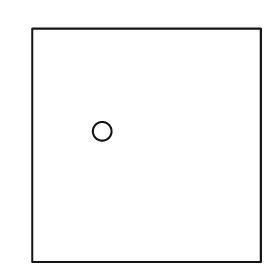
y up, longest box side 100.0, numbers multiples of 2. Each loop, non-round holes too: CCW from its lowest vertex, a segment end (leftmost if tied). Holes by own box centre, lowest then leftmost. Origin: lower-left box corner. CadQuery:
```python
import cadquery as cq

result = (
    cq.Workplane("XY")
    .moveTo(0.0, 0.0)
    .lineTo(98.0, 0.0)
    .lineTo(98.0, 100.0)
    .lineTo(0.0, 100.0)
    .close()
    .moveTo(30.0, 56.0)
    .circle(4.0)
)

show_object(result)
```